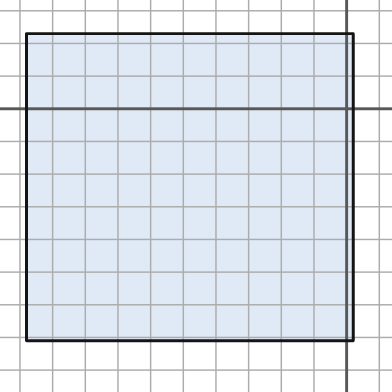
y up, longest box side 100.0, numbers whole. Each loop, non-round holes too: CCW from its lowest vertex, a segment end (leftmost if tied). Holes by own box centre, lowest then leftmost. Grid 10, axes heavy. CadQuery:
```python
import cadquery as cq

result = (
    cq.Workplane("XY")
    .moveTo(-98.0, -71.0)
    .lineTo(2.0, -71.0)
    .lineTo(2.0, 23.0)
    .lineTo(-98.0, 23.0)
    .close()
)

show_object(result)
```